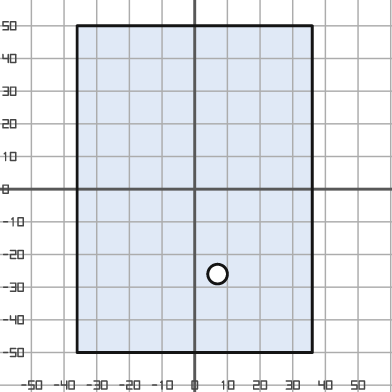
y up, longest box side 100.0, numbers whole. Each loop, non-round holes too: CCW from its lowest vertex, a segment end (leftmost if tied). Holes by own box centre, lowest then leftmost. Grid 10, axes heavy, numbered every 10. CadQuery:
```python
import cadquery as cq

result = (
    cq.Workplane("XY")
    .moveTo(-36.0, -50.0)
    .lineTo(36.0, -50.0)
    .lineTo(36.0, 50.0)
    .lineTo(-36.0, 50.0)
    .close()
    .moveTo(7.0, -26.0)
    .circle(3.0)
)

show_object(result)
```